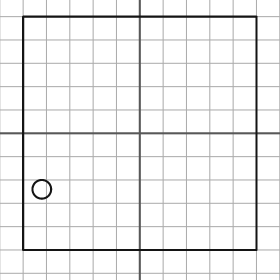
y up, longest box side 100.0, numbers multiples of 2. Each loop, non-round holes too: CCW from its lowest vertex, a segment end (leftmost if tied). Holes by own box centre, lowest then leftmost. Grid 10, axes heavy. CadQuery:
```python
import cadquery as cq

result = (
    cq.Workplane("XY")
    .moveTo(-50.0, -50.0)
    .lineTo(50.0, -50.0)
    .lineTo(50.0, 50.0)
    .lineTo(-50.0, 50.0)
    .close()
    .moveTo(-42.0, -24.0)
    .circle(4.0)
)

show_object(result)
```